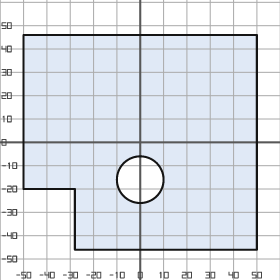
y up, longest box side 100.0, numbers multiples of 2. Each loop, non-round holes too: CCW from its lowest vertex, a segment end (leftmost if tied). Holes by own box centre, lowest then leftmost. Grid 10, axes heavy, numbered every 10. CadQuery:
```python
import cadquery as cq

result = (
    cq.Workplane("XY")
    .moveTo(-28.0, -46.0)
    .lineTo(50.0, -46.0)
    .lineTo(50.0, 46.0)
    .lineTo(-50.0, 46.0)
    .lineTo(-50.0, -20.0)
    .lineTo(-28.0, -20.0)
    .close()
    .moveTo(0.0, -16.0)
    .circle(10.0)
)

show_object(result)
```